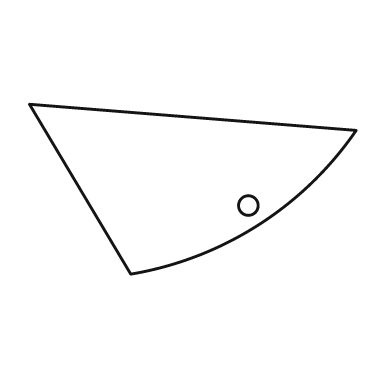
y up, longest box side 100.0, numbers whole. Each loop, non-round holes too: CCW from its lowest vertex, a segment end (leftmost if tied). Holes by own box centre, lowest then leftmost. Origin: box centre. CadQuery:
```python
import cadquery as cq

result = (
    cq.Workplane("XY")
    .moveTo(-19.0, -26.0)
    .threePointArc((20.0, -11.0), (50.0, 18.0))
    .lineTo(-50.0, 26.0)
    .close()
    .moveTo(17.0, -5.0)
    .circle(3.0)
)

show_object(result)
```